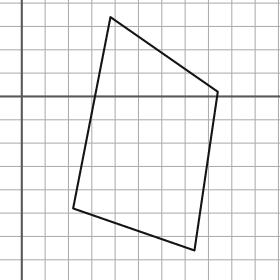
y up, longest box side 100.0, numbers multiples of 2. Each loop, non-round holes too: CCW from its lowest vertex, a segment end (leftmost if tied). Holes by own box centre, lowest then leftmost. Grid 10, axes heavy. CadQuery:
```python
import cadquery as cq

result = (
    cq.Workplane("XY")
    .moveTo(74.0, -66.0)
    .lineTo(84.0, 2.0)
    .lineTo(38.0, 34.0)
    .lineTo(22.0, -48.0)
    .close()
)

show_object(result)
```